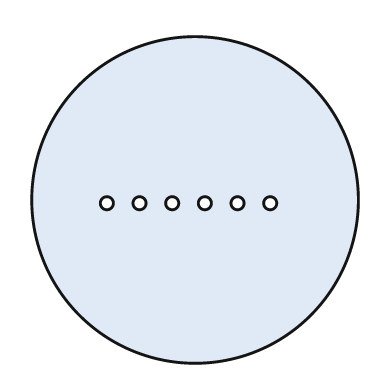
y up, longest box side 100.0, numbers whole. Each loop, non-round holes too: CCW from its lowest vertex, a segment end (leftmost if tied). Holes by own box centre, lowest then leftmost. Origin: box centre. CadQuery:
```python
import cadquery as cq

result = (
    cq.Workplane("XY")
    .moveTo(0.0, 0.0)
    .circle(50.0)
    .moveTo(-27.0, -1.0)
    .circle(2.0)
    .moveTo(-17.0, -1.0)
    .circle(2.0)
    .moveTo(-7.0, -1.0)
    .circle(2.0)
    .moveTo(3.0, -1.0)
    .circle(2.0)
    .moveTo(13.0, -1.0)
    .circle(2.0)
    .moveTo(23.0, -1.0)
    .circle(2.0)
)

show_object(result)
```